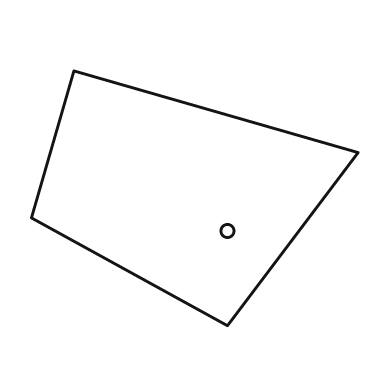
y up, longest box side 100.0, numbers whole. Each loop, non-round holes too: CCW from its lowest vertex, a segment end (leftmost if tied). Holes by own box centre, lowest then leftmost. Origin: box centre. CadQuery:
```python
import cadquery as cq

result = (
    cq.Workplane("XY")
    .moveTo(10.0, -39.0)
    .lineTo(50.0, 14.0)
    .lineTo(-37.0, 39.0)
    .lineTo(-50.0, -6.0)
    .close()
    .moveTo(10.0, -10.0)
    .circle(2.0)
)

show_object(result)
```